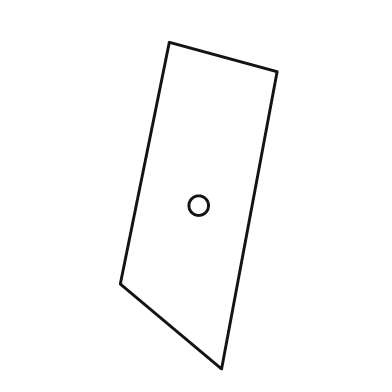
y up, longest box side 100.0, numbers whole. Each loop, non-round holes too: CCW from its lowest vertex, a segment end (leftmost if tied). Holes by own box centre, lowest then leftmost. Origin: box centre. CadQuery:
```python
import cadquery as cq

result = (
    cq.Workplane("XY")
    .moveTo(7.0, -50.0)
    .lineTo(24.0, 41.0)
    .lineTo(-9.0, 50.0)
    .lineTo(-24.0, -24.0)
    .close()
    .moveTo(0.0, 0.0)
    .circle(3.0)
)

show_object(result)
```